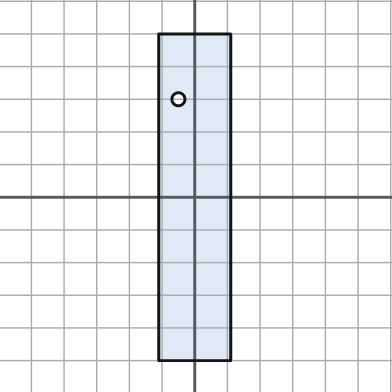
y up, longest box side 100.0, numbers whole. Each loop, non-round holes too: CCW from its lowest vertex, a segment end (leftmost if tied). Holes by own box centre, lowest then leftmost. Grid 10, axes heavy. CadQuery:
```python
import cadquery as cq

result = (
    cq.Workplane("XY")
    .moveTo(-11.0, -50.0)
    .lineTo(11.0, -50.0)
    .lineTo(11.0, 50.0)
    .lineTo(-11.0, 50.0)
    .close()
    .moveTo(-5.0, 30.0)
    .circle(2.0)
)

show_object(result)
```